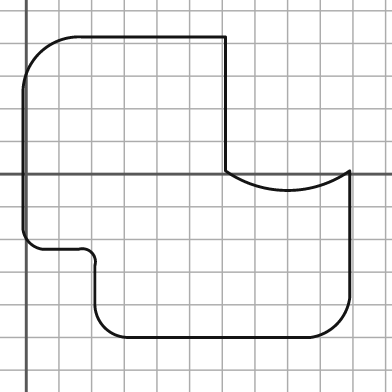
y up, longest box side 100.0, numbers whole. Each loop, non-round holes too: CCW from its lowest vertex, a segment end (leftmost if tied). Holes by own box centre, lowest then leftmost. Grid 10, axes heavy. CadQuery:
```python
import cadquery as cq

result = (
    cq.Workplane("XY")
    .moveTo(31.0, -50.0)
    .lineTo(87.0, -50.0)
    .threePointArc((95.0, -46.0), (99.0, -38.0))
    .lineTo(99.0, 1.0)
    .threePointArc((80.0, -5.0), (61.0, 1.0))
    .lineTo(61.0, 42.0)
    .lineTo(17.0, 42.0)
    .threePointArc((4.0, 37.0), (-1.0, 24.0))
    .lineTo(-1.0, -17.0)
    .threePointArc((1.0, -21.0), (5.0, -23.0))
    .lineTo(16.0, -23.0)
    .threePointArc((20.0, -24.0), (21.0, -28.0))
    .lineTo(21.0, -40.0)
    .threePointArc((24.0, -47.0), (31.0, -50.0))
    .close()
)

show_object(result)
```